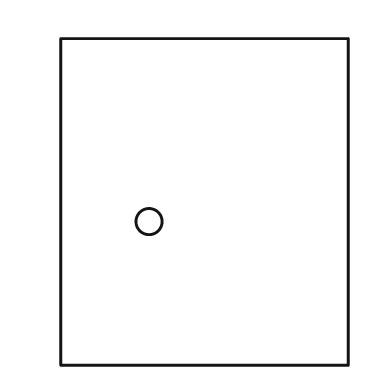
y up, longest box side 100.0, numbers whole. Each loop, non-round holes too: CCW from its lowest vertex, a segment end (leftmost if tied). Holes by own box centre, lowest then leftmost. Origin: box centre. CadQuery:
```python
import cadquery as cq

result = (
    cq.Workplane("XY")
    .moveTo(-44.0, -50.0)
    .lineTo(44.0, -50.0)
    .lineTo(44.0, 50.0)
    .lineTo(-44.0, 50.0)
    .close()
    .moveTo(-17.0, -6.0)
    .circle(4.0)
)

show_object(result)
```